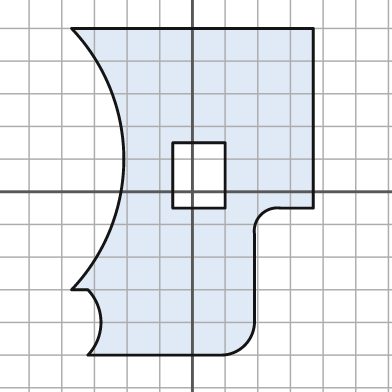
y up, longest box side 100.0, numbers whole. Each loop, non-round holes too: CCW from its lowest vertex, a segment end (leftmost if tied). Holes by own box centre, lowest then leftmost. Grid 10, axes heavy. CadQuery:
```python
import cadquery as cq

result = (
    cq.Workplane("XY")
    .moveTo(-32.0, -50.0)
    .lineTo(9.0, -50.0)
    .threePointArc((16.0, -47.0), (19.0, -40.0))
    .lineTo(19.0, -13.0)
    .threePointArc((21.0, -7.0), (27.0, -5.0))
    .lineTo(37.0, -5.0)
    .lineTo(37.0, 50.0)
    .lineTo(-37.0, 50.0)
    .threePointArc((-21.0, 10.0), (-37.0, -30.0))
    .lineTo(-32.0, -30.0)
    .threePointArc((-28.0, -40.0), (-32.0, -50.0))
    .close()
    .moveTo(-6.0, -5.0)
    .lineTo(10.0, -5.0)
    .lineTo(10.0, 15.0)
    .lineTo(-6.0, 15.0)
    .close()
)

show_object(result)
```